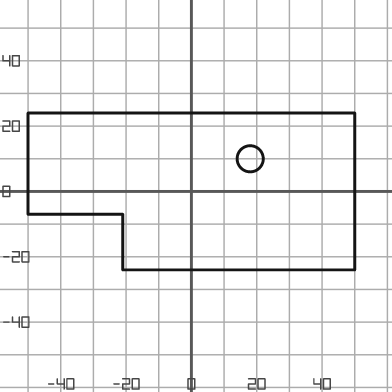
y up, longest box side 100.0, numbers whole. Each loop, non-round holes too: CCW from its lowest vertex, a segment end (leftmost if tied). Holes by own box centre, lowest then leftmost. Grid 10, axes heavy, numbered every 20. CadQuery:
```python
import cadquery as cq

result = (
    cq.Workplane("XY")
    .moveTo(-21.0, -24.0)
    .lineTo(50.0, -24.0)
    .lineTo(50.0, 24.0)
    .lineTo(-50.0, 24.0)
    .lineTo(-50.0, -7.0)
    .lineTo(-21.0, -7.0)
    .close()
    .moveTo(18.0, 10.0)
    .circle(4.0)
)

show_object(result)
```